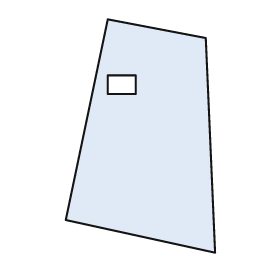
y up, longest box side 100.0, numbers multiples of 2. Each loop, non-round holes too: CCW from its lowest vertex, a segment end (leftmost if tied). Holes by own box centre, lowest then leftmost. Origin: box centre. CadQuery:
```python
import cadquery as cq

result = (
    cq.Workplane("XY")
    .moveTo(32.0, -50.0)
    .lineTo(28.0, 42.0)
    .lineTo(-14.0, 50.0)
    .lineTo(-32.0, -36.0)
    .close()
    .moveTo(-14.0, 18.0)
    .lineTo(-2.0, 18.0)
    .lineTo(-2.0, 26.0)
    .lineTo(-14.0, 26.0)
    .close()
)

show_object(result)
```